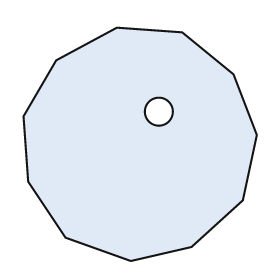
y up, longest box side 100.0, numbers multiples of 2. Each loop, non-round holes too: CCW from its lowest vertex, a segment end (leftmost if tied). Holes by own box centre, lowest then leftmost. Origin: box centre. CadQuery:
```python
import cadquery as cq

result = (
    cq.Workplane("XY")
    .moveTo(-4.0, -50.0)
    .lineTo(22.0, -44.0)
    .lineTo(44.0, -24.0)
    .lineTo(50.0, 4.0)
    .lineTo(40.0, 30.0)
    .lineTo(18.0, 48.0)
    .lineTo(-10.0, 50.0)
    .lineTo(-36.0, 36.0)
    .lineTo(-50.0, 12.0)
    .lineTo(-48.0, -16.0)
    .lineTo(-32.0, -40.0)
    .close()
    .moveTo(8.0, 14.0)
    .circle(6.0)
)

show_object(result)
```